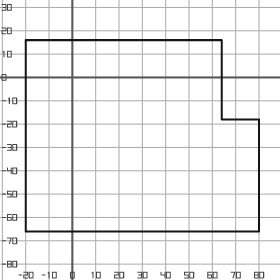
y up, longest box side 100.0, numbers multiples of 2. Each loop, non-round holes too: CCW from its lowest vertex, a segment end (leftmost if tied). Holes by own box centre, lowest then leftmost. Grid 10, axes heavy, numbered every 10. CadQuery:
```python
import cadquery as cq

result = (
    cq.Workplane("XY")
    .moveTo(-20.0, -66.0)
    .lineTo(80.0, -66.0)
    .lineTo(80.0, -18.0)
    .lineTo(64.0, -18.0)
    .lineTo(64.0, 16.0)
    .lineTo(-20.0, 16.0)
    .close()
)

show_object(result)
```